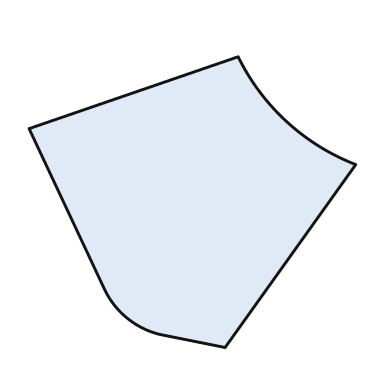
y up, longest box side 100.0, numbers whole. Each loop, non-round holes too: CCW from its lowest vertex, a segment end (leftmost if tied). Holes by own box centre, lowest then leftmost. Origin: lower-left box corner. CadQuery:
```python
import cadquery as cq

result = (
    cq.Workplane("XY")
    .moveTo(60.0, 0.0)
    .lineTo(100.0, 56.0)
    .threePointArc((79.0, 69.0), (64.0, 89.0))
    .lineTo(0.0, 67.0)
    .lineTo(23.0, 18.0)
    .threePointArc((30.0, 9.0), (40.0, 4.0))
    .close()
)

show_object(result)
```